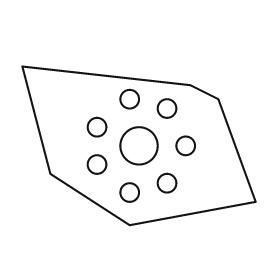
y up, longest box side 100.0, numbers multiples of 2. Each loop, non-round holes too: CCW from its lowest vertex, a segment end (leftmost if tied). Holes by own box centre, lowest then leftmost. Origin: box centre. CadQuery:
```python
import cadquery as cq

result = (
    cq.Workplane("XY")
    .moveTo(-4.0, -34.0)
    .lineTo(50.0, -24.0)
    .lineTo(34.0, 20.0)
    .lineTo(22.0, 26.0)
    .lineTo(-50.0, 34.0)
    .lineTo(-38.0, -12.0)
    .close()
    .moveTo(-4.0, -20.0)
    .circle(4.0)
    .moveTo(12.0, -16.0)
    .circle(4.0)
    .moveTo(-18.0, -8.0)
    .circle(4.0)
    .moveTo(0.0, 0.0)
    .circle(8.0)
    .moveTo(20.0, 0.0)
    .circle(4.0)
    .moveTo(-18.0, 8.0)
    .circle(4.0)
    .moveTo(12.0, 16.0)
    .circle(4.0)
    .moveTo(-4.0, 20.0)
    .circle(4.0)
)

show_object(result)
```